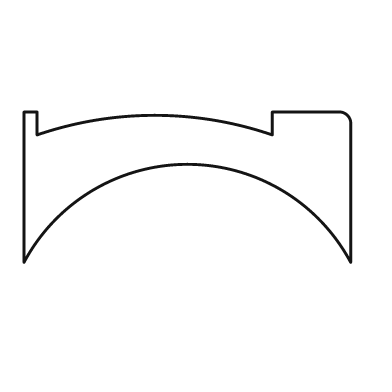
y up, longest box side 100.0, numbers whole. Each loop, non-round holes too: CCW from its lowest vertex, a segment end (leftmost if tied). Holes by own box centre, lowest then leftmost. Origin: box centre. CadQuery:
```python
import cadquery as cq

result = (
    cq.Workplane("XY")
    .moveTo(-50.0, -23.0)
    .threePointArc((0.0, 7.0), (50.0, -23.0))
    .lineTo(50.0, 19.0)
    .threePointArc((49.0, 22.0), (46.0, 23.0))
    .lineTo(26.0, 23.0)
    .lineTo(26.0, 16.0)
    .threePointArc((-10.0, 22.0), (-46.0, 16.0))
    .lineTo(-46.0, 23.0)
    .lineTo(-50.0, 23.0)
    .close()
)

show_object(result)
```